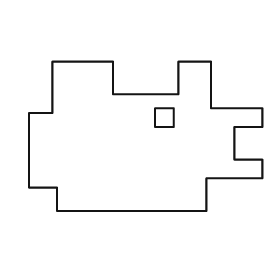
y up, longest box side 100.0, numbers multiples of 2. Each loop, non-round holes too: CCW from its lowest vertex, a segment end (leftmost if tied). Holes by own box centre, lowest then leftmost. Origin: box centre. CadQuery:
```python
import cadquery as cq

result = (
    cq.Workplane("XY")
    .moveTo(-38.0, -32.0)
    .lineTo(26.0, -32.0)
    .lineTo(26.0, -18.0)
    .lineTo(50.0, -18.0)
    .lineTo(50.0, -10.0)
    .lineTo(38.0, -10.0)
    .lineTo(38.0, 4.0)
    .lineTo(50.0, 4.0)
    .lineTo(50.0, 12.0)
    .lineTo(28.0, 12.0)
    .lineTo(28.0, 32.0)
    .lineTo(14.0, 32.0)
    .lineTo(14.0, 18.0)
    .lineTo(-14.0, 18.0)
    .lineTo(-14.0, 32.0)
    .lineTo(-40.0, 32.0)
    .lineTo(-40.0, 10.0)
    .lineTo(-50.0, 10.0)
    .lineTo(-50.0, -22.0)
    .lineTo(-38.0, -22.0)
    .close()
    .moveTo(4.0, 4.0)
    .lineTo(12.0, 4.0)
    .lineTo(12.0, 12.0)
    .lineTo(4.0, 12.0)
    .close()
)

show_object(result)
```